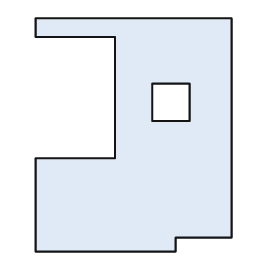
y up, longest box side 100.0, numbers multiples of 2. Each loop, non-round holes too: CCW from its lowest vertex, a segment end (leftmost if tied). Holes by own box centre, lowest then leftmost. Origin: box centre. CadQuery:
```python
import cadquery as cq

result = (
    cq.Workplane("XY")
    .moveTo(-42.0, -50.0)
    .lineTo(18.0, -50.0)
    .lineTo(18.0, -44.0)
    .lineTo(42.0, -44.0)
    .lineTo(42.0, 50.0)
    .lineTo(-42.0, 50.0)
    .lineTo(-42.0, 42.0)
    .lineTo(-8.0, 42.0)
    .lineTo(-8.0, -10.0)
    .lineTo(-42.0, -10.0)
    .close()
    .moveTo(8.0, 6.0)
    .lineTo(24.0, 6.0)
    .lineTo(24.0, 22.0)
    .lineTo(8.0, 22.0)
    .close()
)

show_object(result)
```